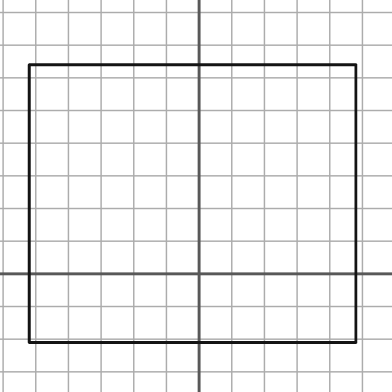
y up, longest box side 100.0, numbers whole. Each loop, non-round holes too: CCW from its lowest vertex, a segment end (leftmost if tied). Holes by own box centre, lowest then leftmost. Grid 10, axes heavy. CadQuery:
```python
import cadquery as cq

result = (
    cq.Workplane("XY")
    .moveTo(-52.0, -21.0)
    .lineTo(48.0, -21.0)
    .lineTo(48.0, 64.0)
    .lineTo(-52.0, 64.0)
    .close()
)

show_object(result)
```